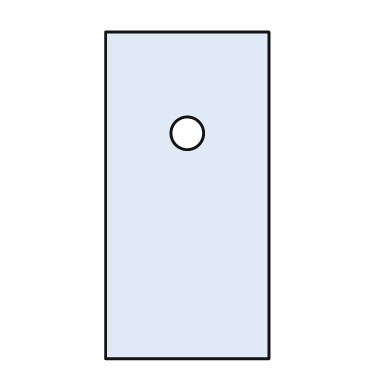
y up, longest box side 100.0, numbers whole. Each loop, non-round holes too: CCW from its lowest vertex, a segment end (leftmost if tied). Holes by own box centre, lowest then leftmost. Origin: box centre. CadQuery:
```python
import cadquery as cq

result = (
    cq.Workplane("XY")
    .moveTo(-25.0, -50.0)
    .lineTo(25.0, -50.0)
    .lineTo(25.0, 50.0)
    .lineTo(-25.0, 50.0)
    .close()
    .moveTo(0.0, 19.0)
    .circle(5.0)
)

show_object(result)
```